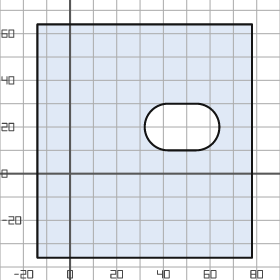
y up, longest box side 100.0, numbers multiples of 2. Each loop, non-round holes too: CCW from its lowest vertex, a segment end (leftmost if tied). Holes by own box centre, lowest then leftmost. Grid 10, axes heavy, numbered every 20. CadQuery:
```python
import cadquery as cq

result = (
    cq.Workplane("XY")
    .moveTo(-14.0, -36.0)
    .lineTo(78.0, -36.0)
    .lineTo(78.0, 64.0)
    .lineTo(-14.0, 64.0)
    .close()
    .moveTo(42.0, 10.0)
    .lineTo(54.0, 10.0)
    .threePointArc((64.0, 20.0), (54.0, 30.0))
    .lineTo(42.0, 30.0)
    .threePointArc((32.0, 20.0), (42.0, 10.0))
    .close()
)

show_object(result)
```